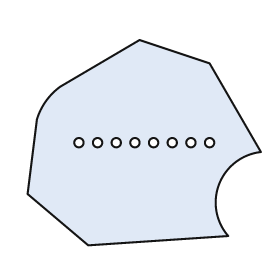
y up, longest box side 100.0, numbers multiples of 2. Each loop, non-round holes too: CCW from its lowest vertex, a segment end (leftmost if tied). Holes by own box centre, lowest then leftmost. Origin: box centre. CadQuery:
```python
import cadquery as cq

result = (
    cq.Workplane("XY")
    .moveTo(-24.0, -44.0)
    .lineTo(36.0, -40.0)
    .threePointArc((32.0, -18.0), (50.0, -4.0))
    .lineTo(28.0, 34.0)
    .lineTo(-2.0, 44.0)
    .lineTo(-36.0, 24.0)
    .threePointArc((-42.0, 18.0), (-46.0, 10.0))
    .lineTo(-50.0, -22.0)
    .close()
    .moveTo(-28.0, 0.0)
    .circle(2.0)
    .moveTo(-20.0, 0.0)
    .circle(2.0)
    .moveTo(-12.0, 0.0)
    .circle(2.0)
    .moveTo(-4.0, 0.0)
    .circle(2.0)
    .moveTo(4.0, 0.0)
    .circle(2.0)
    .moveTo(12.0, 0.0)
    .circle(2.0)
    .moveTo(20.0, 0.0)
    .circle(2.0)
    .moveTo(28.0, 0.0)
    .circle(2.0)
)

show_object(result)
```